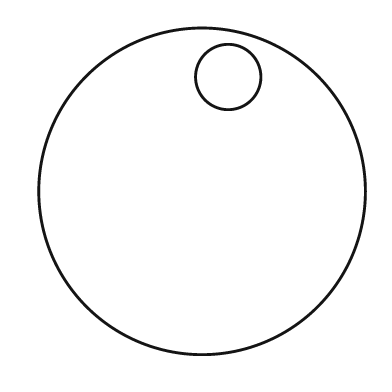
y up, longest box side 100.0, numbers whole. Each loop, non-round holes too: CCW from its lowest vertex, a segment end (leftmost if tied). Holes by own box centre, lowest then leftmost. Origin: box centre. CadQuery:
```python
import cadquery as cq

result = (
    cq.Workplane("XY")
    .moveTo(0.0, 0.0)
    .circle(50.0)
    .moveTo(8.0, 35.0)
    .circle(10.0)
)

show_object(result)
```